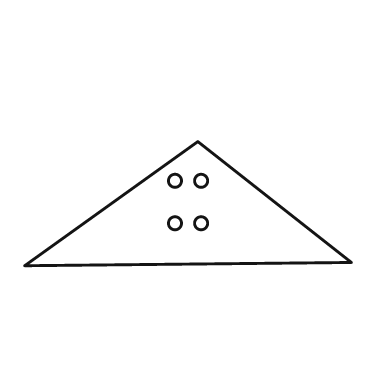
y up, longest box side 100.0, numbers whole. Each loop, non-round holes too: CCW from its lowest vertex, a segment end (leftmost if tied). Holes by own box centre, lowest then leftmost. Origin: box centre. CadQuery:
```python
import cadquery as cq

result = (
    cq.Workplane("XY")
    .moveTo(-50.0, -19.0)
    .lineTo(50.0, -18.0)
    .lineTo(3.0, 19.0)
    .close()
    .moveTo(-4.0, -6.0)
    .circle(2.0)
    .moveTo(4.0, -6.0)
    .circle(2.0)
    .moveTo(-4.0, 7.0)
    .circle(2.0)
    .moveTo(4.0, 7.0)
    .circle(2.0)
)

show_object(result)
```